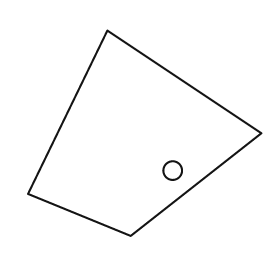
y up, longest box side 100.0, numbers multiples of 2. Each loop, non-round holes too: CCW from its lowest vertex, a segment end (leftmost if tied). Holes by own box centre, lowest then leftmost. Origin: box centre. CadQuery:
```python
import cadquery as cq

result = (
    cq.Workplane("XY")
    .moveTo(-6.0, -44.0)
    .lineTo(50.0, 0.0)
    .lineTo(-16.0, 44.0)
    .lineTo(-50.0, -26.0)
    .close()
    .moveTo(12.0, -16.0)
    .circle(4.0)
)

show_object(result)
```